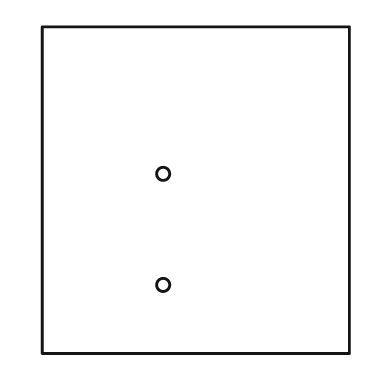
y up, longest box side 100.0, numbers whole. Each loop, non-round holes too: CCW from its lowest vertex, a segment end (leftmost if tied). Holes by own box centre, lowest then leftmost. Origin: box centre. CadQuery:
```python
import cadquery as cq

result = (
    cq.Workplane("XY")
    .moveTo(-47.0, -50.0)
    .lineTo(47.0, -50.0)
    .lineTo(47.0, 50.0)
    .lineTo(-47.0, 50.0)
    .close()
    .moveTo(-10.0, -29.0)
    .circle(2.0)
    .moveTo(-10.0, 5.0)
    .circle(2.0)
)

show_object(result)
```